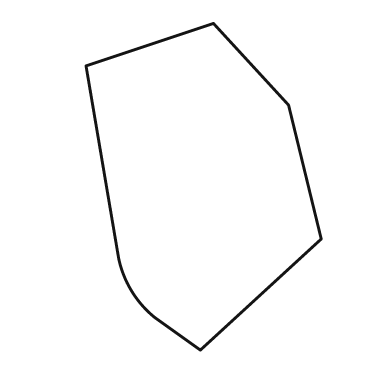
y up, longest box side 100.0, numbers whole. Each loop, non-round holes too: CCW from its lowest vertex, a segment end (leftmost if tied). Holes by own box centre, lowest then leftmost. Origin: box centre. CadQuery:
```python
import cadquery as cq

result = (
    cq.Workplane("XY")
    .moveTo(-1.0, -50.0)
    .lineTo(36.0, -16.0)
    .lineTo(26.0, 25.0)
    .lineTo(3.0, 50.0)
    .lineTo(-36.0, 37.0)
    .lineTo(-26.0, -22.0)
    .threePointArc((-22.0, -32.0), (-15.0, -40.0))
    .close()
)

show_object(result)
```